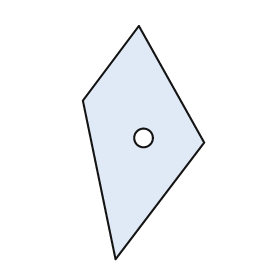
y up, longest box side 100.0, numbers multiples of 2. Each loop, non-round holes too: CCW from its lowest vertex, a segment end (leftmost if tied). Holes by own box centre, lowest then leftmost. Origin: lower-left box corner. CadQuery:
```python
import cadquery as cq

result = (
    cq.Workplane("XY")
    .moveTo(14.0, 0.0)
    .lineTo(52.0, 50.0)
    .lineTo(24.0, 100.0)
    .lineTo(0.0, 68.0)
    .close()
    .moveTo(26.0, 52.0)
    .circle(4.0)
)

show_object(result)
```